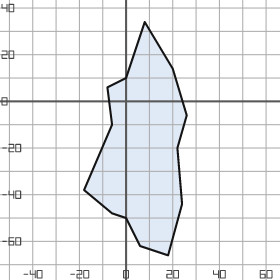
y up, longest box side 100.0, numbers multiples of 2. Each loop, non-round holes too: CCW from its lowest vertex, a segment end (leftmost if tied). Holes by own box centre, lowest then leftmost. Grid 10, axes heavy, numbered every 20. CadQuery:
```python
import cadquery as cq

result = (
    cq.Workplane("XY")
    .moveTo(18.0, -66.0)
    .lineTo(24.0, -44.0)
    .lineTo(22.0, -20.0)
    .lineTo(26.0, -6.0)
    .lineTo(20.0, 14.0)
    .lineTo(8.0, 34.0)
    .lineTo(0.0, 10.0)
    .lineTo(-8.0, 6.0)
    .lineTo(-6.0, -10.0)
    .lineTo(-18.0, -38.0)
    .lineTo(-6.0, -48.0)
    .lineTo(0.0, -50.0)
    .lineTo(6.0, -62.0)
    .close()
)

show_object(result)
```